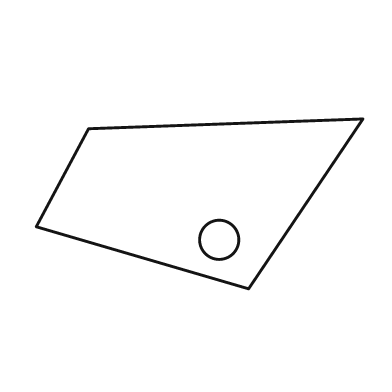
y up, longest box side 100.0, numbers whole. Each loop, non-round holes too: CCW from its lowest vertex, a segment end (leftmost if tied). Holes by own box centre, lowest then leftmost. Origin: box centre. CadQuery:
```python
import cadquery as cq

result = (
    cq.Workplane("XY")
    .moveTo(15.0, -26.0)
    .lineTo(50.0, 26.0)
    .lineTo(-34.0, 23.0)
    .lineTo(-50.0, -7.0)
    .close()
    .moveTo(6.0, -11.0)
    .circle(6.0)
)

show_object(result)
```